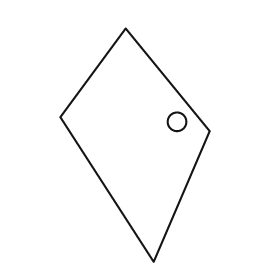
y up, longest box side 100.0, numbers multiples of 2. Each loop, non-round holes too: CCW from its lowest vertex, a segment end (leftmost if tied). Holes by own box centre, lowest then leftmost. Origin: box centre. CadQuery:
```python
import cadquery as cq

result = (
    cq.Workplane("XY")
    .moveTo(8.0, -50.0)
    .lineTo(32.0, 6.0)
    .lineTo(-4.0, 50.0)
    .lineTo(-32.0, 12.0)
    .close()
    .moveTo(18.0, 10.0)
    .circle(4.0)
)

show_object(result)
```